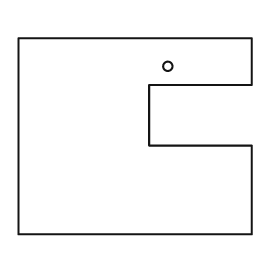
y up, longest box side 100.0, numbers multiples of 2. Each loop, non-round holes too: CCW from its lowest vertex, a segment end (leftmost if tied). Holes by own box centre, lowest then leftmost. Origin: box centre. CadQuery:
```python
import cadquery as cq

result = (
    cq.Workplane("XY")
    .moveTo(-50.0, -42.0)
    .lineTo(50.0, -42.0)
    .lineTo(50.0, -4.0)
    .lineTo(6.0, -4.0)
    .lineTo(6.0, 22.0)
    .lineTo(50.0, 22.0)
    .lineTo(50.0, 42.0)
    .lineTo(-50.0, 42.0)
    .close()
    .moveTo(14.0, 30.0)
    .circle(2.0)
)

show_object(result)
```